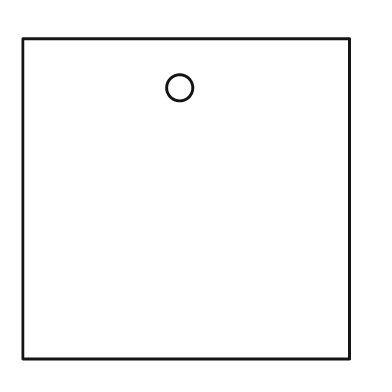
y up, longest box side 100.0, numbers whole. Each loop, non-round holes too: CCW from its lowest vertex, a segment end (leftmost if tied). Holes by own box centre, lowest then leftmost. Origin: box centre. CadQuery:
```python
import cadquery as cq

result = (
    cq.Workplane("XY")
    .moveTo(-50.0, -49.0)
    .lineTo(50.0, -49.0)
    .lineTo(50.0, 49.0)
    .lineTo(-50.0, 49.0)
    .close()
    .moveTo(-2.0, 34.0)
    .circle(4.0)
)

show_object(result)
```